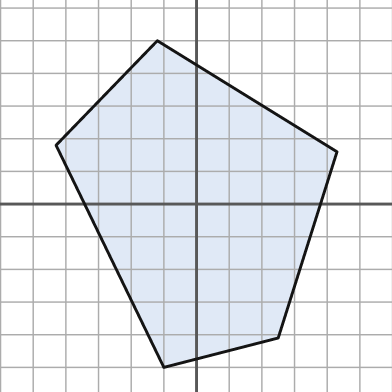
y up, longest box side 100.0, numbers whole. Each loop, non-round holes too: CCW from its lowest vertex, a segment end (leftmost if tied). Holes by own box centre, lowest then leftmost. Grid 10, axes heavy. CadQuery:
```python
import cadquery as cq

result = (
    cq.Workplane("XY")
    .moveTo(-10.0, -50.0)
    .lineTo(25.0, -41.0)
    .lineTo(43.0, 16.0)
    .lineTo(-12.0, 50.0)
    .lineTo(-43.0, 18.0)
    .close()
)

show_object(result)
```